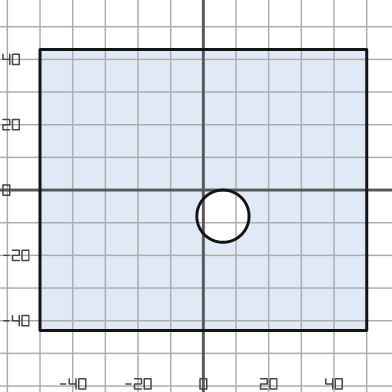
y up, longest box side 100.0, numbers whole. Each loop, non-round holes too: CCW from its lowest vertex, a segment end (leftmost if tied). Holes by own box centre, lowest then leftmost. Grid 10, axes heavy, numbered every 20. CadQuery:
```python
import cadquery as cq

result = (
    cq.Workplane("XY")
    .moveTo(-50.0, -43.0)
    .lineTo(50.0, -43.0)
    .lineTo(50.0, 43.0)
    .lineTo(-50.0, 43.0)
    .close()
    .moveTo(6.0, -8.0)
    .circle(8.0)
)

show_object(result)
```